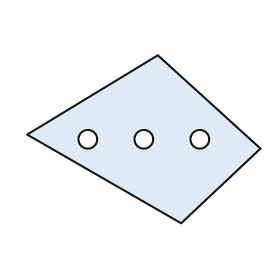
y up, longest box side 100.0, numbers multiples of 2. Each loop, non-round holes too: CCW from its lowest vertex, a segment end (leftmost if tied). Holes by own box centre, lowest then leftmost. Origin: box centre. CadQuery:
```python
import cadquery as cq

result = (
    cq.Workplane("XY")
    .moveTo(16.0, -36.0)
    .lineTo(50.0, -4.0)
    .lineTo(6.0, 36.0)
    .lineTo(-50.0, 2.0)
    .close()
    .moveTo(-24.0, 0.0)
    .circle(4.0)
    .moveTo(0.0, 0.0)
    .circle(4.0)
    .moveTo(24.0, 0.0)
    .circle(4.0)
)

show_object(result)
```